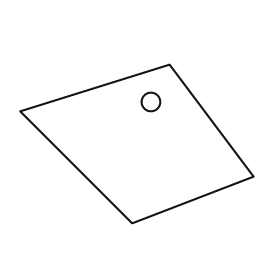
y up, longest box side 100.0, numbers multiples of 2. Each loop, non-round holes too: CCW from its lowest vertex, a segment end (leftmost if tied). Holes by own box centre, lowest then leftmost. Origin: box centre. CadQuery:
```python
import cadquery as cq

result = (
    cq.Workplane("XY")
    .moveTo(-2.0, -34.0)
    .lineTo(50.0, -14.0)
    .lineTo(14.0, 34.0)
    .lineTo(-50.0, 14.0)
    .close()
    .moveTo(6.0, 18.0)
    .circle(4.0)
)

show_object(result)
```